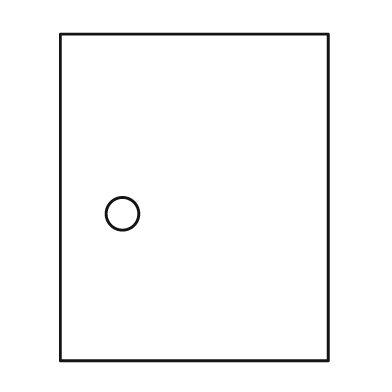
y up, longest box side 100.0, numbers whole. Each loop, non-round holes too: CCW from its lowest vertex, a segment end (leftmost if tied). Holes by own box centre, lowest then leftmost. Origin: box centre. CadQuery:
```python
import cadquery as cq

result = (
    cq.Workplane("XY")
    .moveTo(-41.0, -50.0)
    .lineTo(41.0, -50.0)
    .lineTo(41.0, 50.0)
    .lineTo(-41.0, 50.0)
    .close()
    .moveTo(-22.0, -5.0)
    .circle(5.0)
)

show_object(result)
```